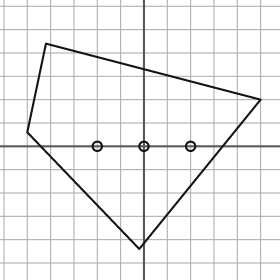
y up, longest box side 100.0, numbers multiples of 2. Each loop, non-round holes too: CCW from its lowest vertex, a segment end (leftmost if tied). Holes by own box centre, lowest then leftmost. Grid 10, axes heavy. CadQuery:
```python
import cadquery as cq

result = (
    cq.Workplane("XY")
    .moveTo(-2.0, -44.0)
    .lineTo(50.0, 20.0)
    .lineTo(-42.0, 44.0)
    .lineTo(-50.0, 6.0)
    .close()
    .moveTo(-20.0, 0.0)
    .circle(2.0)
    .moveTo(0.0, 0.0)
    .circle(2.0)
    .moveTo(20.0, 0.0)
    .circle(2.0)
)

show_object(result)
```